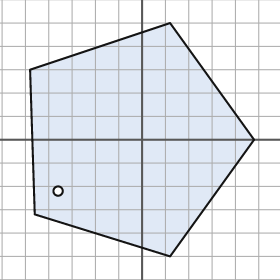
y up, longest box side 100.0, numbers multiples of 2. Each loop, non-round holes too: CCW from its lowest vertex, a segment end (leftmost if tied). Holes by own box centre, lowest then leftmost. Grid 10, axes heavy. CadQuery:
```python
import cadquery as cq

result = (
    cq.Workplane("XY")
    .moveTo(12.0, -50.0)
    .lineTo(48.0, 0.0)
    .lineTo(12.0, 50.0)
    .lineTo(-48.0, 30.0)
    .lineTo(-46.0, -32.0)
    .close()
    .moveTo(-36.0, -22.0)
    .circle(2.0)
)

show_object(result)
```